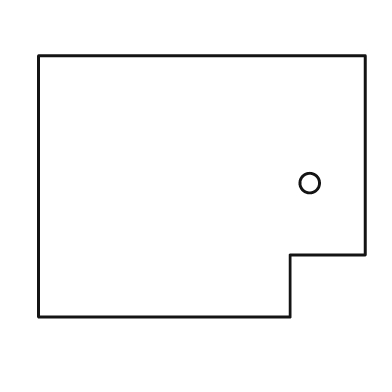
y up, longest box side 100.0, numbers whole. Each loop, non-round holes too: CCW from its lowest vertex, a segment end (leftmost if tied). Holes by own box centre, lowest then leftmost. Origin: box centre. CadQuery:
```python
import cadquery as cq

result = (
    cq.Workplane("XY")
    .moveTo(-50.0, -40.0)
    .lineTo(27.0, -40.0)
    .lineTo(27.0, -21.0)
    .lineTo(50.0, -21.0)
    .lineTo(50.0, 40.0)
    .lineTo(-50.0, 40.0)
    .close()
    .moveTo(33.0, 1.0)
    .circle(3.0)
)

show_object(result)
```